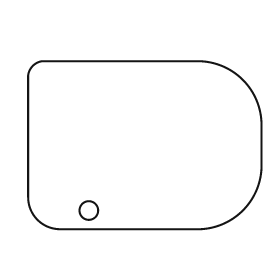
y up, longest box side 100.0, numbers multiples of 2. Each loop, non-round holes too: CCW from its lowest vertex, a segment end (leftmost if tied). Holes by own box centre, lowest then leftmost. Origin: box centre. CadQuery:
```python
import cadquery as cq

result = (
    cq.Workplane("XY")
    .moveTo(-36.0, -36.0)
    .lineTo(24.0, -36.0)
    .threePointArc((42.0, -28.0), (50.0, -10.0))
    .lineTo(50.0, 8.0)
    .threePointArc((42.0, 28.0), (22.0, 36.0))
    .lineTo(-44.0, 36.0)
    .threePointArc((-48.0, 34.0), (-50.0, 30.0))
    .lineTo(-50.0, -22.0)
    .threePointArc((-46.0, -32.0), (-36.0, -36.0))
    .close()
    .moveTo(-24.0, -28.0)
    .circle(4.0)
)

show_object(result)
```